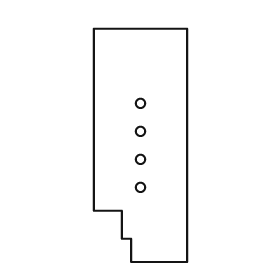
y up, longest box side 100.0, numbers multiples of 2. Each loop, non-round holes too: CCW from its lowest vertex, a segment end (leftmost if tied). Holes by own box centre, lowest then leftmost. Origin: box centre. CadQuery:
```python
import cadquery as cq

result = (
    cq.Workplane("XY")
    .moveTo(-4.0, -50.0)
    .lineTo(20.0, -50.0)
    .lineTo(20.0, 50.0)
    .lineTo(-20.0, 50.0)
    .lineTo(-20.0, -28.0)
    .lineTo(-8.0, -28.0)
    .lineTo(-8.0, -40.0)
    .lineTo(-4.0, -40.0)
    .close()
    .moveTo(0.0, -18.0)
    .circle(2.0)
    .moveTo(0.0, -6.0)
    .circle(2.0)
    .moveTo(0.0, 6.0)
    .circle(2.0)
    .moveTo(0.0, 18.0)
    .circle(2.0)
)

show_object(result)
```